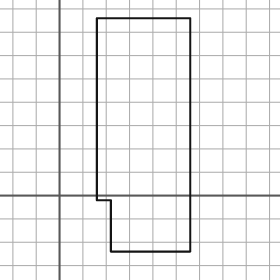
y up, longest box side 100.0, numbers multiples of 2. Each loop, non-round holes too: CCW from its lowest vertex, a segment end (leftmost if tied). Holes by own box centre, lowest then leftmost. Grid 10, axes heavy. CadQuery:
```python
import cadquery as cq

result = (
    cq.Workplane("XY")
    .moveTo(22.0, -24.0)
    .lineTo(56.0, -24.0)
    .lineTo(56.0, 76.0)
    .lineTo(16.0, 76.0)
    .lineTo(16.0, -2.0)
    .lineTo(22.0, -2.0)
    .close()
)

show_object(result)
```